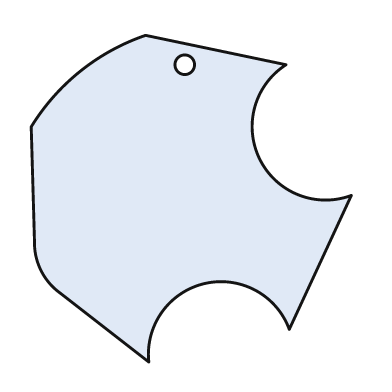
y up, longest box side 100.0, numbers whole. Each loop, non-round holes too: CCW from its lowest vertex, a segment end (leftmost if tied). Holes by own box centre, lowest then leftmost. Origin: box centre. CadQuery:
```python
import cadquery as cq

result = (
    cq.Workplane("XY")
    .moveTo(-13.0, -50.0)
    .threePointArc((4.0, -26.0), (30.0, -40.0))
    .lineTo(49.0, 1.0)
    .threePointArc((21.0, 12.0), (29.0, 41.0))
    .lineTo(-14.0, 50.0)
    .threePointArc((-34.0, 39.0), (-49.0, 22.0))
    .lineTo(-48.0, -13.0)
    .threePointArc((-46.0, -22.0), (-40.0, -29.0))
    .close()
    .moveTo(-2.0, 41.0)
    .circle(3.0)
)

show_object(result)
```